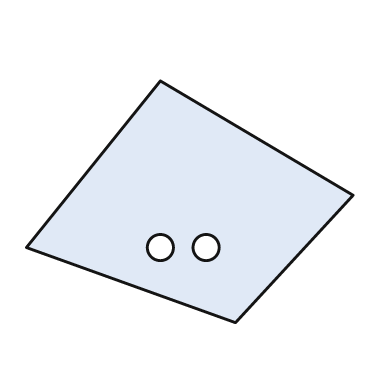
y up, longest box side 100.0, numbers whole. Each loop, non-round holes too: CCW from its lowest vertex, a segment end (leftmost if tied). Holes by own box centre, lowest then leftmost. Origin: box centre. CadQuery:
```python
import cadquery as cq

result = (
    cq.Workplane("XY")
    .moveTo(14.0, -37.0)
    .lineTo(50.0, 2.0)
    .lineTo(-9.0, 37.0)
    .lineTo(-50.0, -14.0)
    .close()
    .moveTo(-9.0, -14.0)
    .circle(4.0)
    .moveTo(5.0, -14.0)
    .circle(4.0)
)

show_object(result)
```